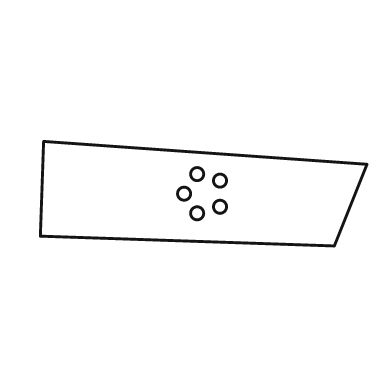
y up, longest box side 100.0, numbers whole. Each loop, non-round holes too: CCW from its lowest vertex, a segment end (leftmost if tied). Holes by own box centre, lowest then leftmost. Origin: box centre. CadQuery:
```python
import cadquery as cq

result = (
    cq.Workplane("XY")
    .moveTo(40.0, -16.0)
    .lineTo(50.0, 9.0)
    .lineTo(-49.0, 16.0)
    .lineTo(-50.0, -13.0)
    .close()
    .moveTo(-2.0, -6.0)
    .circle(2.0)
    .moveTo(5.0, -4.0)
    .circle(2.0)
    .moveTo(-6.0, 0.0)
    .circle(2.0)
    .moveTo(5.0, 4.0)
    .circle(2.0)
    .moveTo(-2.0, 6.0)
    .circle(2.0)
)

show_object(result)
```